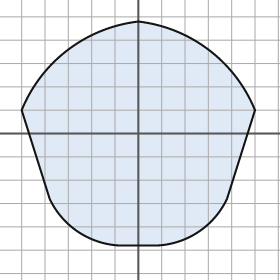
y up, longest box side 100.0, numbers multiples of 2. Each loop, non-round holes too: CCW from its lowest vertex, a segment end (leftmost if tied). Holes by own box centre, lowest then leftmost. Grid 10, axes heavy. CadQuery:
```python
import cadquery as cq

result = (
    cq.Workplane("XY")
    .moveTo(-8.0, -48.0)
    .lineTo(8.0, -48.0)
    .threePointArc((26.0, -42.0), (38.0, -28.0))
    .lineTo(50.0, 10.0)
    .threePointArc((30.0, 36.0), (0.0, 48.0))
    .threePointArc((-30.0, 36.0), (-50.0, 10.0))
    .lineTo(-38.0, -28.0)
    .threePointArc((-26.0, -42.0), (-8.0, -48.0))
    .close()
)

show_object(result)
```